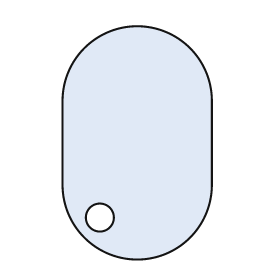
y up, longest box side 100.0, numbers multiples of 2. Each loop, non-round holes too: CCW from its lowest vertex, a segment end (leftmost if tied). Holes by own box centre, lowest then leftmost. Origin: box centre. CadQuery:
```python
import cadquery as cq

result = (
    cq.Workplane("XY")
    .moveTo(-32.0, -18.0)
    .threePointArc((0.0, -50.0), (32.0, -18.0))
    .lineTo(32.0, 18.0)
    .threePointArc((0.0, 50.0), (-32.0, 18.0))
    .close()
    .moveTo(-16.0, -32.0)
    .circle(6.0)
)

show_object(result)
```